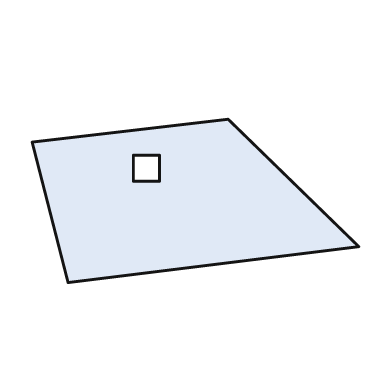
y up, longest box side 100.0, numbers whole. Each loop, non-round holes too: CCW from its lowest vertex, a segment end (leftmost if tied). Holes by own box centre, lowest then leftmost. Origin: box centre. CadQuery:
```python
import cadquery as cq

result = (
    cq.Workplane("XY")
    .moveTo(-39.0, -25.0)
    .lineTo(50.0, -14.0)
    .lineTo(10.0, 25.0)
    .lineTo(-50.0, 18.0)
    .close()
    .moveTo(-19.0, 6.0)
    .lineTo(-11.0, 6.0)
    .lineTo(-11.0, 14.0)
    .lineTo(-19.0, 14.0)
    .close()
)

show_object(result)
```